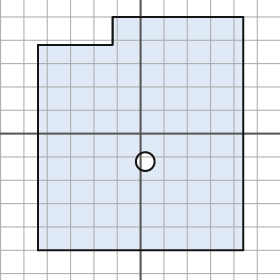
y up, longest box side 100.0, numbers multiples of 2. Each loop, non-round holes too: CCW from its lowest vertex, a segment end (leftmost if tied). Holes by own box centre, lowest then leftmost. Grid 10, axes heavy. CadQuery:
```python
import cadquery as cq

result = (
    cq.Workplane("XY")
    .moveTo(-44.0, -50.0)
    .lineTo(44.0, -50.0)
    .lineTo(44.0, 50.0)
    .lineTo(-12.0, 50.0)
    .lineTo(-12.0, 38.0)
    .lineTo(-44.0, 38.0)
    .close()
    .moveTo(2.0, -12.0)
    .circle(4.0)
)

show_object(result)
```